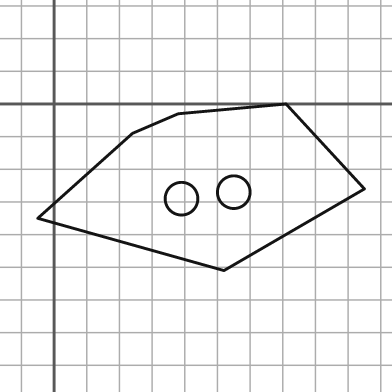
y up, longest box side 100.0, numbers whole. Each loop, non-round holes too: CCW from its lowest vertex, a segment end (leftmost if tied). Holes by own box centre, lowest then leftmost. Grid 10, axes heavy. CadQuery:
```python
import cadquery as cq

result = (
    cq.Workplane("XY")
    .moveTo(52.0, -51.0)
    .lineTo(95.0, -26.0)
    .lineTo(71.0, 0.0)
    .lineTo(38.0, -3.0)
    .lineTo(24.0, -9.0)
    .lineTo(-5.0, -35.0)
    .close()
    .moveTo(39.0, -29.0)
    .circle(5.0)
    .moveTo(55.0, -27.0)
    .circle(5.0)
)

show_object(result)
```